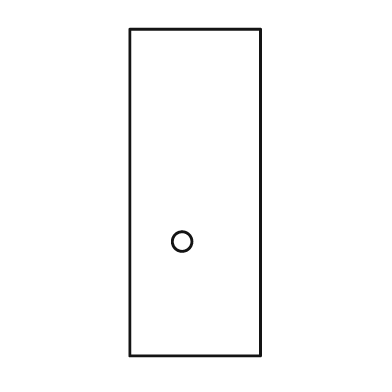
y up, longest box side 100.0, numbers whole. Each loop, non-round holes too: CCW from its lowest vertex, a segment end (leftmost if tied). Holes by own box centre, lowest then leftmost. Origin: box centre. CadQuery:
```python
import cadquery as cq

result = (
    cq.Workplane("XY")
    .moveTo(-20.0, -50.0)
    .lineTo(20.0, -50.0)
    .lineTo(20.0, 50.0)
    .lineTo(-20.0, 50.0)
    .close()
    .moveTo(-4.0, -15.0)
    .circle(3.0)
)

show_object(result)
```